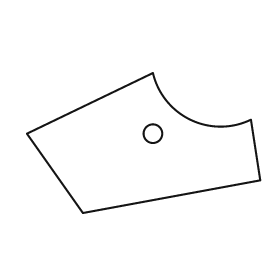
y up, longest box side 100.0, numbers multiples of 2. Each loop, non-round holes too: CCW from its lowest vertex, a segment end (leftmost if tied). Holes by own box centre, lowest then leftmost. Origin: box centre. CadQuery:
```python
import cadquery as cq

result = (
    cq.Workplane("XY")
    .moveTo(-26.0, -30.0)
    .lineTo(50.0, -16.0)
    .lineTo(46.0, 10.0)
    .threePointArc((20.0, 10.0), (4.0, 30.0))
    .lineTo(-50.0, 4.0)
    .close()
    .moveTo(4.0, 4.0)
    .circle(4.0)
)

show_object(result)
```